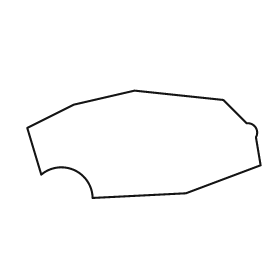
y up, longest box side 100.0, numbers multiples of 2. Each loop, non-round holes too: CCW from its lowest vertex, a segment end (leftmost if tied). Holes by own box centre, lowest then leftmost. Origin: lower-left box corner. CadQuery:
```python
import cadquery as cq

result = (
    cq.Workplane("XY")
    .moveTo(28.0, 0.0)
    .lineTo(68.0, 2.0)
    .lineTo(100.0, 14.0)
    .lineTo(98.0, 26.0)
    .threePointArc((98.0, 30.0), (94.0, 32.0))
    .lineTo(84.0, 42.0)
    .lineTo(46.0, 46.0)
    .lineTo(20.0, 40.0)
    .lineTo(0.0, 30.0)
    .lineTo(6.0, 10.0)
    .threePointArc((20.0, 12.0), (28.0, 0.0))
    .close()
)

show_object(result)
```